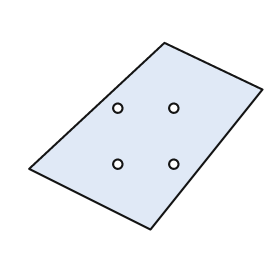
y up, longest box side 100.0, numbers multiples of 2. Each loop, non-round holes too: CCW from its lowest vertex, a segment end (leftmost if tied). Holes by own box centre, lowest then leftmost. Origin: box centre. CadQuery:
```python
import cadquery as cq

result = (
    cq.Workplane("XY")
    .moveTo(2.0, -40.0)
    .lineTo(50.0, 20.0)
    .lineTo(8.0, 40.0)
    .lineTo(-50.0, -14.0)
    .close()
    .moveTo(-12.0, -12.0)
    .circle(2.0)
    .moveTo(12.0, -12.0)
    .circle(2.0)
    .moveTo(-12.0, 12.0)
    .circle(2.0)
    .moveTo(12.0, 12.0)
    .circle(2.0)
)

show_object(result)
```